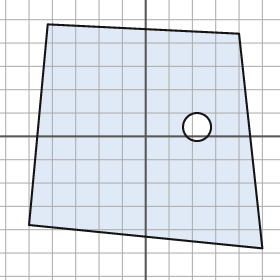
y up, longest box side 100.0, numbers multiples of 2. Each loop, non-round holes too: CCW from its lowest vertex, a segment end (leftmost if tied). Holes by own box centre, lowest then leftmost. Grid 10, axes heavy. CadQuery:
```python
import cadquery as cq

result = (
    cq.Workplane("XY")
    .moveTo(50.0, -48.0)
    .lineTo(40.0, 44.0)
    .lineTo(-42.0, 48.0)
    .lineTo(-50.0, -38.0)
    .close()
    .moveTo(22.0, 4.0)
    .circle(6.0)
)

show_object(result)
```